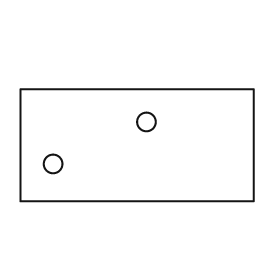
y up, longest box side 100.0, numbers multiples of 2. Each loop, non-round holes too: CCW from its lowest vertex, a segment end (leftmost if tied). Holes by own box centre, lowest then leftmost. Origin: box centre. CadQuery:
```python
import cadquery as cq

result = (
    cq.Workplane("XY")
    .moveTo(-50.0, -24.0)
    .lineTo(50.0, -24.0)
    .lineTo(50.0, 24.0)
    .lineTo(-50.0, 24.0)
    .close()
    .moveTo(-36.0, -8.0)
    .circle(4.0)
    .moveTo(4.0, 10.0)
    .circle(4.0)
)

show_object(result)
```